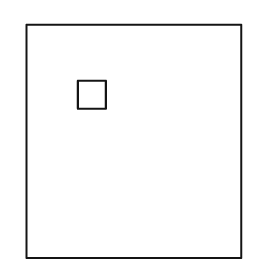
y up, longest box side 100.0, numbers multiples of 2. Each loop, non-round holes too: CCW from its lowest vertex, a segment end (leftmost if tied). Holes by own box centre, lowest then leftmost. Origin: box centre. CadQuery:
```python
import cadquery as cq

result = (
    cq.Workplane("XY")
    .moveTo(-46.0, -50.0)
    .lineTo(46.0, -50.0)
    .lineTo(46.0, 50.0)
    .lineTo(-46.0, 50.0)
    .close()
    .moveTo(-24.0, 14.0)
    .lineTo(-12.0, 14.0)
    .lineTo(-12.0, 26.0)
    .lineTo(-24.0, 26.0)
    .close()
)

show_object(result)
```